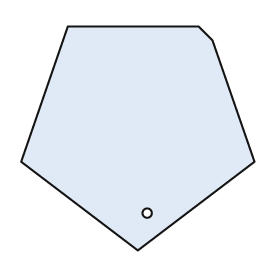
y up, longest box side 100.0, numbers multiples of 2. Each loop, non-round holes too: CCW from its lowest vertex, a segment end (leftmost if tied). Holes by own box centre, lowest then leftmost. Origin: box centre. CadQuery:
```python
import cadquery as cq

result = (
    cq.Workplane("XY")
    .moveTo(0.0, -48.0)
    .lineTo(50.0, -10.0)
    .lineTo(32.0, 42.0)
    .lineTo(26.0, 48.0)
    .lineTo(-30.0, 48.0)
    .lineTo(-50.0, -10.0)
    .close()
    .moveTo(4.0, -32.0)
    .circle(2.0)
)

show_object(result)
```